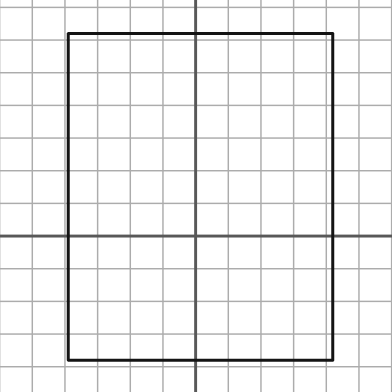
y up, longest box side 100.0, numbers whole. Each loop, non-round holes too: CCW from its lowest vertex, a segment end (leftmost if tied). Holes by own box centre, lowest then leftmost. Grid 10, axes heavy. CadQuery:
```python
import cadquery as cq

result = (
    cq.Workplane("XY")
    .moveTo(-39.0, -38.0)
    .lineTo(42.0, -38.0)
    .lineTo(42.0, 62.0)
    .lineTo(-39.0, 62.0)
    .close()
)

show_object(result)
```